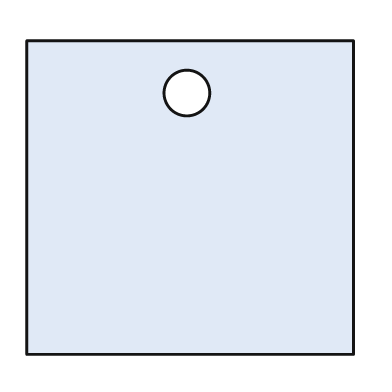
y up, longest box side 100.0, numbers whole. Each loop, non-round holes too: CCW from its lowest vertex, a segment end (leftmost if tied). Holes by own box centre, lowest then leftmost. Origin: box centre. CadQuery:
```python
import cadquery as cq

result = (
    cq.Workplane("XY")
    .moveTo(-50.0, -48.0)
    .lineTo(50.0, -48.0)
    .lineTo(50.0, 48.0)
    .lineTo(-50.0, 48.0)
    .close()
    .moveTo(-1.0, 32.0)
    .circle(7.0)
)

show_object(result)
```